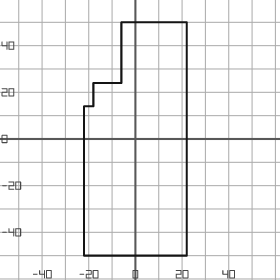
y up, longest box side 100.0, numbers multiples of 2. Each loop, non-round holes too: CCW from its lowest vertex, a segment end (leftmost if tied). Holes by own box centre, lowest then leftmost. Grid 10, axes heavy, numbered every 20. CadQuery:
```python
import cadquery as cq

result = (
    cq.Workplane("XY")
    .moveTo(-22.0, -50.0)
    .lineTo(22.0, -50.0)
    .lineTo(22.0, 50.0)
    .lineTo(-6.0, 50.0)
    .lineTo(-6.0, 24.0)
    .lineTo(-18.0, 24.0)
    .lineTo(-18.0, 14.0)
    .lineTo(-22.0, 14.0)
    .close()
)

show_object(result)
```